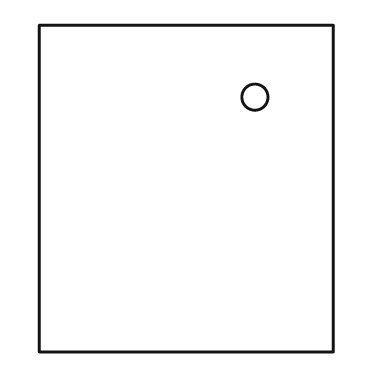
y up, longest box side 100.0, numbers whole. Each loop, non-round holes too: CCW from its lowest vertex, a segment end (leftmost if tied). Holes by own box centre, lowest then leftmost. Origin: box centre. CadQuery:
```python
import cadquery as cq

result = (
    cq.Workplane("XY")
    .moveTo(-45.0, -50.0)
    .lineTo(45.0, -50.0)
    .lineTo(45.0, 50.0)
    .lineTo(-45.0, 50.0)
    .close()
    .moveTo(21.0, 28.0)
    .circle(4.0)
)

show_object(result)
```